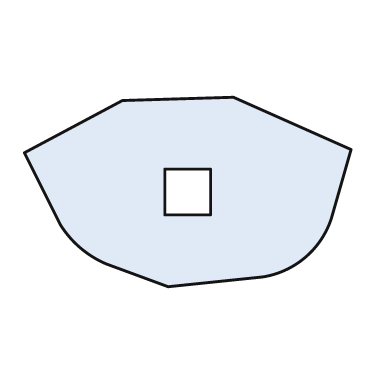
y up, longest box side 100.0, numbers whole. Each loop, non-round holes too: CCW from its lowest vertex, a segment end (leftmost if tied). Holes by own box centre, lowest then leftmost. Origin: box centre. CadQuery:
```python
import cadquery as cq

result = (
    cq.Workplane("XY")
    .moveTo(-6.0, -29.0)
    .lineTo(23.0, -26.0)
    .threePointArc((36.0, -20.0), (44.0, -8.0))
    .lineTo(50.0, 13.0)
    .lineTo(14.0, 29.0)
    .lineTo(-20.0, 28.0)
    .lineTo(-50.0, 12.0)
    .lineTo(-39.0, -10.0)
    .threePointArc((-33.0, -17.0), (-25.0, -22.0))
    .close()
    .moveTo(-7.0, -7.0)
    .lineTo(7.0, -7.0)
    .lineTo(7.0, 7.0)
    .lineTo(-7.0, 7.0)
    .close()
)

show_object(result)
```